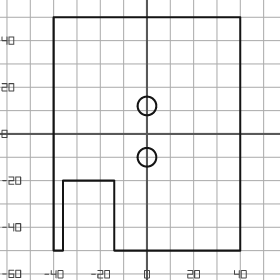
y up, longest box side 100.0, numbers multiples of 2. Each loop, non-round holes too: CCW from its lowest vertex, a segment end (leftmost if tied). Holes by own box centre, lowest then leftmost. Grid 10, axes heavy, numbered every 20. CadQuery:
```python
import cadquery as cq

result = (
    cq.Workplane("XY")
    .moveTo(-40.0, -50.0)
    .lineTo(-36.0, -50.0)
    .lineTo(-36.0, -20.0)
    .lineTo(-14.0, -20.0)
    .lineTo(-14.0, -50.0)
    .lineTo(40.0, -50.0)
    .lineTo(40.0, 50.0)
    .lineTo(-40.0, 50.0)
    .close()
    .moveTo(0.0, -10.0)
    .circle(4.0)
    .moveTo(0.0, 12.0)
    .circle(4.0)
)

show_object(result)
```